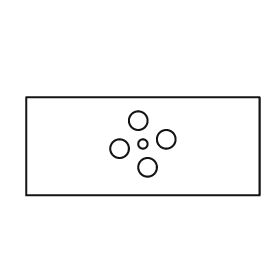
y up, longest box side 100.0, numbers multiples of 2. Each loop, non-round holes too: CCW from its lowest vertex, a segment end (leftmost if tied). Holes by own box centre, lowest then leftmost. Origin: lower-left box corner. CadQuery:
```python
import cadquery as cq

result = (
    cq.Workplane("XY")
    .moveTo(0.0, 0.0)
    .lineTo(100.0, 0.0)
    .lineTo(100.0, 42.0)
    .lineTo(0.0, 42.0)
    .close()
    .moveTo(52.0, 12.0)
    .circle(4.0)
    .moveTo(40.0, 20.0)
    .circle(4.0)
    .moveTo(50.0, 22.0)
    .circle(2.0)
    .moveTo(60.0, 24.0)
    .circle(4.0)
    .moveTo(48.0, 32.0)
    .circle(4.0)
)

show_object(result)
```